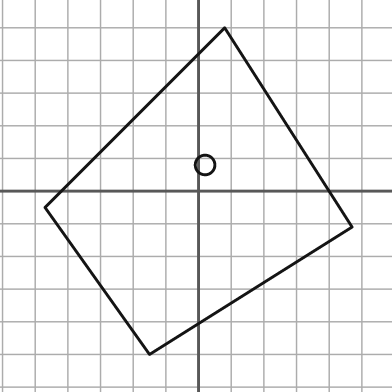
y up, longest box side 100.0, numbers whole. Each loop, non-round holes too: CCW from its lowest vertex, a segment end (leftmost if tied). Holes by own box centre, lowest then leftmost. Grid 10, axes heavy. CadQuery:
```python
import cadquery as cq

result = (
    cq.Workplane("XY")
    .moveTo(-15.0, -50.0)
    .lineTo(47.0, -11.0)
    .lineTo(8.0, 50.0)
    .lineTo(-47.0, -5.0)
    .close()
    .moveTo(2.0, 8.0)
    .circle(3.0)
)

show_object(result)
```